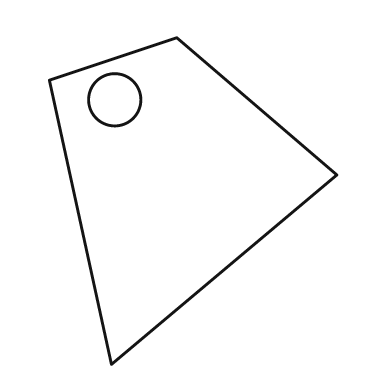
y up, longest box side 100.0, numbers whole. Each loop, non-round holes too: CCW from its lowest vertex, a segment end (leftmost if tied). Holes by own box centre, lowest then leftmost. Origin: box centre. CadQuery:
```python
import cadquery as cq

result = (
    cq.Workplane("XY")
    .moveTo(-25.0, -50.0)
    .lineTo(44.0, 8.0)
    .lineTo(-5.0, 50.0)
    .lineTo(-44.0, 37.0)
    .close()
    .moveTo(-24.0, 31.0)
    .circle(8.0)
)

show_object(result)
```